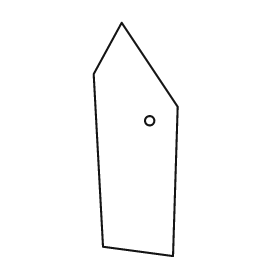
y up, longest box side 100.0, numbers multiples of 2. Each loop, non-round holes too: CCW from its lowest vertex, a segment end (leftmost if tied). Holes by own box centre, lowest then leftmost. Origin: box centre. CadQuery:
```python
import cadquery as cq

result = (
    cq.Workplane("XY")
    .moveTo(16.0, -50.0)
    .lineTo(18.0, 14.0)
    .lineTo(-6.0, 50.0)
    .lineTo(-18.0, 28.0)
    .lineTo(-14.0, -46.0)
    .close()
    .moveTo(6.0, 8.0)
    .circle(2.0)
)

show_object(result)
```